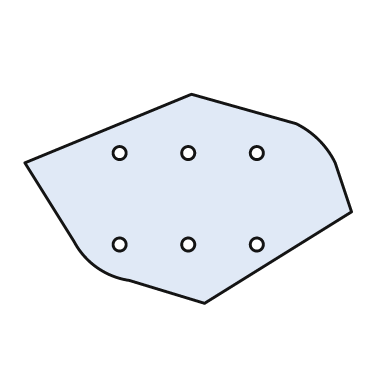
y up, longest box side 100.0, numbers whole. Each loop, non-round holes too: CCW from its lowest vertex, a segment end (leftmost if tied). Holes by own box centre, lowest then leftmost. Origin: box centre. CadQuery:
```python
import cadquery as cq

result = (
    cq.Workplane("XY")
    .moveTo(5.0, -32.0)
    .lineTo(50.0, -4.0)
    .lineTo(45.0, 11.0)
    .threePointArc((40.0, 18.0), (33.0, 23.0))
    .lineTo(1.0, 32.0)
    .lineTo(-50.0, 11.0)
    .lineTo(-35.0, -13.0)
    .threePointArc((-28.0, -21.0), (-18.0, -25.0))
    .close()
    .moveTo(-21.0, -14.0)
    .circle(2.0)
    .moveTo(0.0, -14.0)
    .circle(2.0)
    .moveTo(21.0, -14.0)
    .circle(2.0)
    .moveTo(-21.0, 14.0)
    .circle(2.0)
    .moveTo(0.0, 14.0)
    .circle(2.0)
    .moveTo(21.0, 14.0)
    .circle(2.0)
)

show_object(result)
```